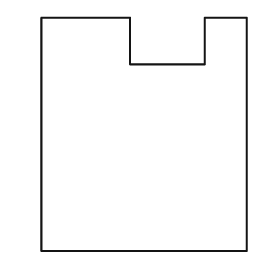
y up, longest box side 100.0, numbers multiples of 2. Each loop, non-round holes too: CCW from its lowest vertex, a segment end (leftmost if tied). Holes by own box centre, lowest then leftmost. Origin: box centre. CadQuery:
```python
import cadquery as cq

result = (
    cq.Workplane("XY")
    .moveTo(-44.0, -50.0)
    .lineTo(44.0, -50.0)
    .lineTo(44.0, 50.0)
    .lineTo(26.0, 50.0)
    .lineTo(26.0, 30.0)
    .lineTo(-6.0, 30.0)
    .lineTo(-6.0, 50.0)
    .lineTo(-44.0, 50.0)
    .close()
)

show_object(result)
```